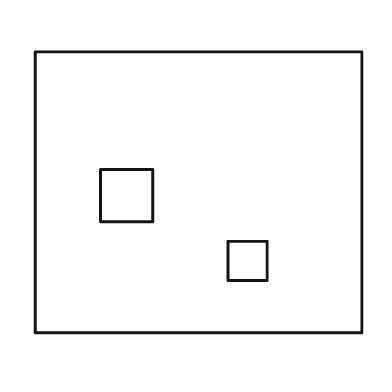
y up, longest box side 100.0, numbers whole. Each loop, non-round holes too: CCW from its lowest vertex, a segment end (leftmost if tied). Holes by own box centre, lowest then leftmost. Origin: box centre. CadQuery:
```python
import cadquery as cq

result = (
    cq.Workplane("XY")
    .moveTo(-50.0, -43.0)
    .lineTo(50.0, -43.0)
    .lineTo(50.0, 43.0)
    .lineTo(-50.0, 43.0)
    .close()
    .moveTo(9.0, -27.0)
    .lineTo(21.0, -27.0)
    .lineTo(21.0, -15.0)
    .lineTo(9.0, -15.0)
    .close()
    .moveTo(-30.0, -9.0)
    .lineTo(-14.0, -9.0)
    .lineTo(-14.0, 7.0)
    .lineTo(-30.0, 7.0)
    .close()
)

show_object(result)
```